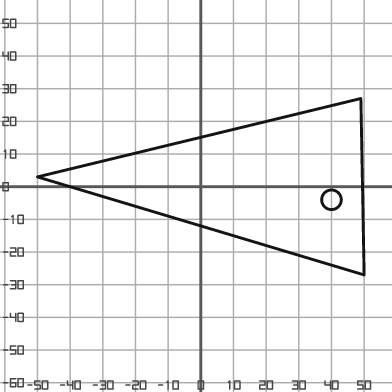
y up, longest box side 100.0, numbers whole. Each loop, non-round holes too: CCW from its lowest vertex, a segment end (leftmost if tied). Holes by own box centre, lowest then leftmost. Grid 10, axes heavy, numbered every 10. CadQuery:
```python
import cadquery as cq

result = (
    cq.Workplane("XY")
    .moveTo(50.0, -27.0)
    .lineTo(49.0, 27.0)
    .lineTo(-50.0, 3.0)
    .close()
    .moveTo(40.0, -4.0)
    .circle(3.0)
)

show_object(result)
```